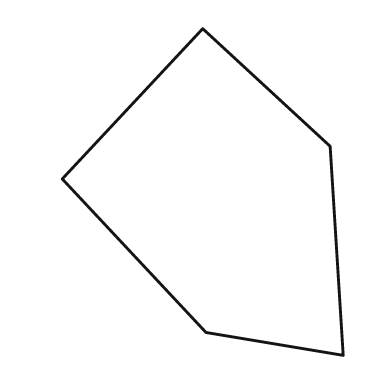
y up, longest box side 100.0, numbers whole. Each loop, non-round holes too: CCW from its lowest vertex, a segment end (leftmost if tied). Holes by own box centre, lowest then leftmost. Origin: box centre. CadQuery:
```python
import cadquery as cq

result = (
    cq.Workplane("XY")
    .moveTo(43.0, -50.0)
    .lineTo(39.0, 14.0)
    .lineTo(0.0, 50.0)
    .lineTo(-43.0, 4.0)
    .lineTo(1.0, -43.0)
    .close()
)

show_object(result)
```